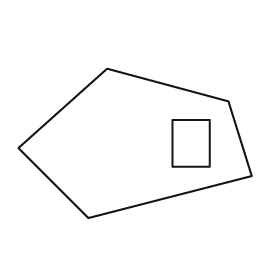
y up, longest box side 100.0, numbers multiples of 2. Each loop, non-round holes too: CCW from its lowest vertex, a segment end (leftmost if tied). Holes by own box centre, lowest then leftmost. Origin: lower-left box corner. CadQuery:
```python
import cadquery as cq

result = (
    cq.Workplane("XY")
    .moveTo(30.0, 0.0)
    .lineTo(100.0, 18.0)
    .lineTo(90.0, 50.0)
    .lineTo(38.0, 64.0)
    .lineTo(0.0, 30.0)
    .close()
    .moveTo(66.0, 22.0)
    .lineTo(82.0, 22.0)
    .lineTo(82.0, 42.0)
    .lineTo(66.0, 42.0)
    .close()
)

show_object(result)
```